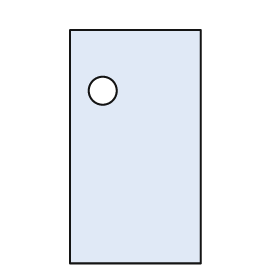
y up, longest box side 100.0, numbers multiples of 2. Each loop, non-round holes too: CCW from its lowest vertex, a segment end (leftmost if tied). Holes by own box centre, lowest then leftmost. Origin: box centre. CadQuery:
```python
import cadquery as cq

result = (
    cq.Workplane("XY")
    .moveTo(-28.0, -50.0)
    .lineTo(28.0, -50.0)
    .lineTo(28.0, 50.0)
    .lineTo(-28.0, 50.0)
    .close()
    .moveTo(-14.0, 24.0)
    .circle(6.0)
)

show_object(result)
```